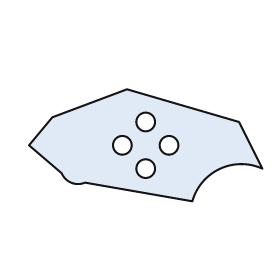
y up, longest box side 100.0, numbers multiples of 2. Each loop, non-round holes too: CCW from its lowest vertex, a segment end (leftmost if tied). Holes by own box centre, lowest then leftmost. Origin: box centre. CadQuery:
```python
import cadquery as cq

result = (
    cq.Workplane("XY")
    .moveTo(20.0, -24.0)
    .threePointArc((32.0, -10.0), (50.0, -10.0))
    .lineTo(40.0, 10.0)
    .lineTo(-8.0, 24.0)
    .lineTo(-40.0, 12.0)
    .lineTo(-50.0, 0.0)
    .lineTo(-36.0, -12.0)
    .threePointArc((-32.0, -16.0), (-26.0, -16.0))
    .close()
    .moveTo(0.0, -10.0)
    .circle(4.0)
    .moveTo(-10.0, 0.0)
    .circle(4.0)
    .moveTo(10.0, 0.0)
    .circle(4.0)
    .moveTo(0.0, 10.0)
    .circle(4.0)
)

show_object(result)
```